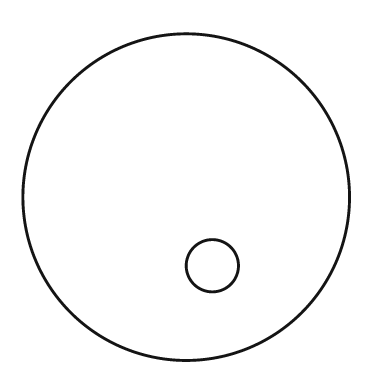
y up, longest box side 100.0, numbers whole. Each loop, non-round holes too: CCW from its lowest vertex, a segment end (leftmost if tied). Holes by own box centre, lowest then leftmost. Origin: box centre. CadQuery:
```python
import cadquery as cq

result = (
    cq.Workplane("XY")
    .moveTo(0.0, 0.0)
    .circle(50.0)
    .moveTo(8.0, -21.0)
    .circle(8.0)
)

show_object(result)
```